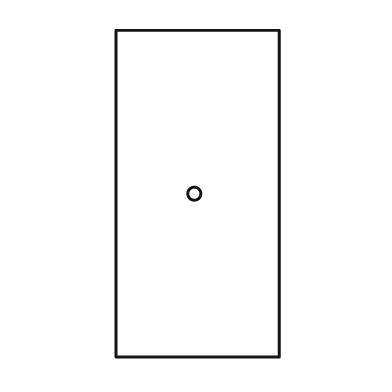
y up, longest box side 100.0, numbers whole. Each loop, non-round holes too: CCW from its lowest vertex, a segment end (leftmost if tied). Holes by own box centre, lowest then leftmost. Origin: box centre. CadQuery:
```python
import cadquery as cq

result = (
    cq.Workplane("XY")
    .moveTo(-25.0, -50.0)
    .lineTo(25.0, -50.0)
    .lineTo(25.0, 50.0)
    .lineTo(-25.0, 50.0)
    .close()
    .moveTo(-1.0, 0.0)
    .circle(2.0)
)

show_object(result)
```